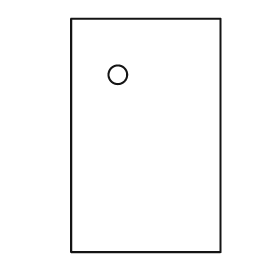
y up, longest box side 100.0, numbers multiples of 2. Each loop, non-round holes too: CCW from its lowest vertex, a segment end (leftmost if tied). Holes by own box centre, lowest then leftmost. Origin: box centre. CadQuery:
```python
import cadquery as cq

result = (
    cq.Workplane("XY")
    .moveTo(-32.0, -50.0)
    .lineTo(32.0, -50.0)
    .lineTo(32.0, 50.0)
    .lineTo(-32.0, 50.0)
    .close()
    .moveTo(-12.0, 26.0)
    .circle(4.0)
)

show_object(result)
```